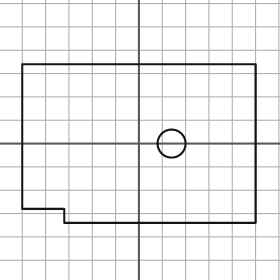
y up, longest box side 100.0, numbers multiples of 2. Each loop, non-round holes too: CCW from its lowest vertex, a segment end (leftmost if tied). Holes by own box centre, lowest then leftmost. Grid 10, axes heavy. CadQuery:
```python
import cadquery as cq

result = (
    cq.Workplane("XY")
    .moveTo(-32.0, -34.0)
    .lineTo(50.0, -34.0)
    .lineTo(50.0, 34.0)
    .lineTo(-50.0, 34.0)
    .lineTo(-50.0, -28.0)
    .lineTo(-32.0, -28.0)
    .close()
    .moveTo(14.0, 0.0)
    .circle(6.0)
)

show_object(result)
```